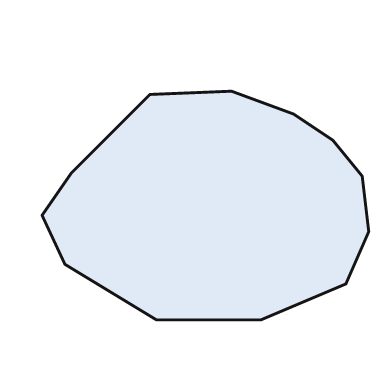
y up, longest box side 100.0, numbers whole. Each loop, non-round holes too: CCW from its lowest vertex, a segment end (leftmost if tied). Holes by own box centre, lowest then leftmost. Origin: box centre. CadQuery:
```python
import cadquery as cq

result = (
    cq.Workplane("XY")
    .moveTo(-15.0, -35.0)
    .lineTo(17.0, -35.0)
    .lineTo(43.0, -24.0)
    .lineTo(50.0, -8.0)
    .lineTo(48.0, 9.0)
    .lineTo(39.0, 20.0)
    .lineTo(27.0, 28.0)
    .lineTo(8.0, 35.0)
    .lineTo(-17.0, 34.0)
    .lineTo(-41.0, 10.0)
    .lineTo(-50.0, -3.0)
    .lineTo(-43.0, -18.0)
    .close()
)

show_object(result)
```